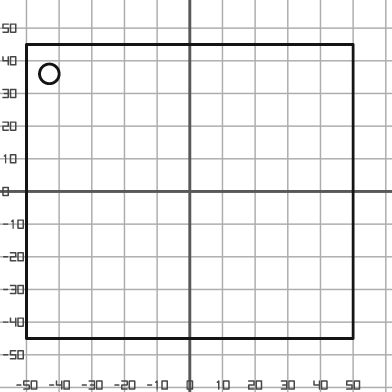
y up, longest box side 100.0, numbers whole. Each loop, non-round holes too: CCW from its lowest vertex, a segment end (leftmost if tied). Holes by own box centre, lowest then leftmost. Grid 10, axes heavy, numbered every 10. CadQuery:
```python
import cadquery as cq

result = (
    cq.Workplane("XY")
    .moveTo(-50.0, -45.0)
    .lineTo(50.0, -45.0)
    .lineTo(50.0, 45.0)
    .lineTo(-50.0, 45.0)
    .close()
    .moveTo(-43.0, 36.0)
    .circle(3.0)
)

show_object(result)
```